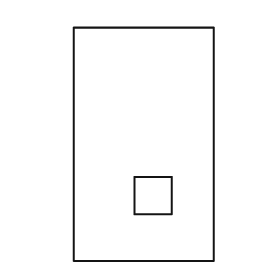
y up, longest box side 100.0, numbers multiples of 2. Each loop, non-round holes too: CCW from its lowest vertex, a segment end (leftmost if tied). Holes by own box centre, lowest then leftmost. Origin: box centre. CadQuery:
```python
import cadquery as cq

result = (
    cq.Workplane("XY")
    .moveTo(-30.0, -50.0)
    .lineTo(30.0, -50.0)
    .lineTo(30.0, 50.0)
    .lineTo(-30.0, 50.0)
    .close()
    .moveTo(-4.0, -30.0)
    .lineTo(12.0, -30.0)
    .lineTo(12.0, -14.0)
    .lineTo(-4.0, -14.0)
    .close()
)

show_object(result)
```